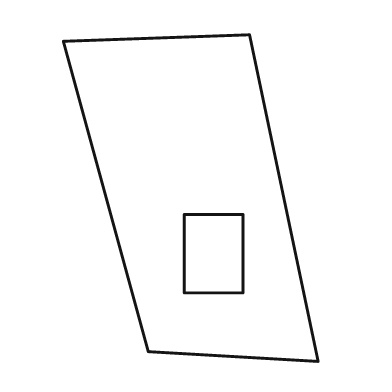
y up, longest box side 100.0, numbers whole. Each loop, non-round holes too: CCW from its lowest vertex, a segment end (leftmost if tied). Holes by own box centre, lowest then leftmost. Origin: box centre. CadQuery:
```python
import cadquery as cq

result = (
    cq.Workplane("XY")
    .moveTo(39.0, -50.0)
    .lineTo(18.0, 50.0)
    .lineTo(-39.0, 48.0)
    .lineTo(-13.0, -47.0)
    .close()
    .moveTo(-2.0, -29.0)
    .lineTo(16.0, -29.0)
    .lineTo(16.0, -5.0)
    .lineTo(-2.0, -5.0)
    .close()
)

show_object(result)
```